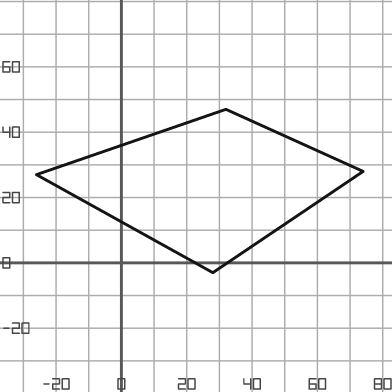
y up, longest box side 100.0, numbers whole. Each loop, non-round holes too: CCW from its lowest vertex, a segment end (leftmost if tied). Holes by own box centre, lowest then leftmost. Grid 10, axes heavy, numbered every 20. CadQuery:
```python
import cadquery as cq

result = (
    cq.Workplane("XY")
    .moveTo(28.0, -3.0)
    .lineTo(74.0, 28.0)
    .lineTo(32.0, 47.0)
    .lineTo(-26.0, 27.0)
    .close()
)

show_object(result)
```